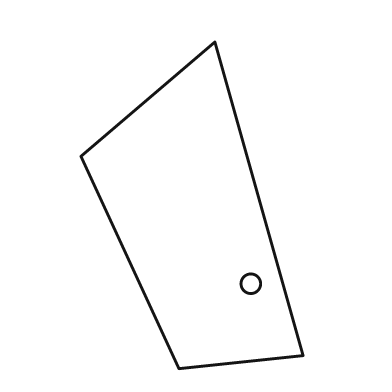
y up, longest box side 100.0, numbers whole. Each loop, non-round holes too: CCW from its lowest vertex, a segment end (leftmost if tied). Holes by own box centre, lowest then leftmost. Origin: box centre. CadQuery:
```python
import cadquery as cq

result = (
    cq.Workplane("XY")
    .moveTo(-4.0, -50.0)
    .lineTo(34.0, -46.0)
    .lineTo(7.0, 50.0)
    .lineTo(-34.0, 15.0)
    .close()
    .moveTo(18.0, -24.0)
    .circle(3.0)
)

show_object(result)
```